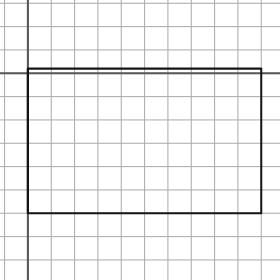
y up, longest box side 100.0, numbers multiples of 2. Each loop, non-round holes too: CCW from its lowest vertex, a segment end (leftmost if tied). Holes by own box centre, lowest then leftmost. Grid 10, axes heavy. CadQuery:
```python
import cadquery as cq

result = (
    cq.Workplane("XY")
    .moveTo(0.0, -60.0)
    .lineTo(100.0, -60.0)
    .lineTo(100.0, 2.0)
    .lineTo(0.0, 2.0)
    .close()
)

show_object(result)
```